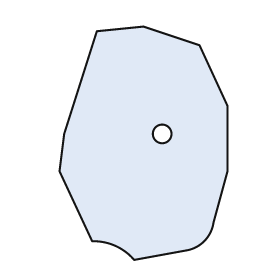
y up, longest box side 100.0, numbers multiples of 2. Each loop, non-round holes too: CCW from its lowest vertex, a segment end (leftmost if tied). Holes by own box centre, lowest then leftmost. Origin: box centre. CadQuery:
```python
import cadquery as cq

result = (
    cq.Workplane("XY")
    .moveTo(-4.0, -50.0)
    .lineTo(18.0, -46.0)
    .threePointArc((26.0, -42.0), (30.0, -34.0))
    .lineTo(36.0, -12.0)
    .lineTo(36.0, 16.0)
    .lineTo(24.0, 42.0)
    .lineTo(0.0, 50.0)
    .lineTo(-20.0, 48.0)
    .lineTo(-34.0, 4.0)
    .lineTo(-36.0, -12.0)
    .lineTo(-22.0, -42.0)
    .threePointArc((-12.0, -44.0), (-4.0, -50.0))
    .close()
    .moveTo(8.0, 4.0)
    .circle(4.0)
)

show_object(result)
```